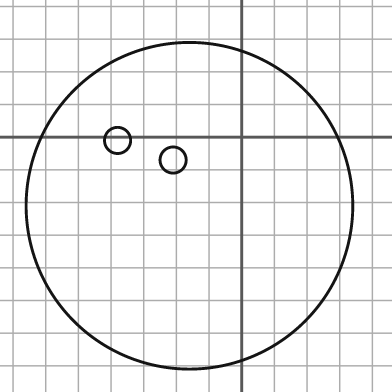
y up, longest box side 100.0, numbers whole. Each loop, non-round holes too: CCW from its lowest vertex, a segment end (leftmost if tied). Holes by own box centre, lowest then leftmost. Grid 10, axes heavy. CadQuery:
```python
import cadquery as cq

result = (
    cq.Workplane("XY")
    .moveTo(-16.0, -21.0)
    .circle(50.0)
    .moveTo(-21.0, -7.0)
    .circle(4.0)
    .moveTo(-38.0, -1.0)
    .circle(4.0)
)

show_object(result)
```